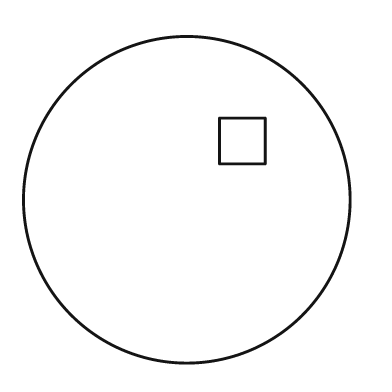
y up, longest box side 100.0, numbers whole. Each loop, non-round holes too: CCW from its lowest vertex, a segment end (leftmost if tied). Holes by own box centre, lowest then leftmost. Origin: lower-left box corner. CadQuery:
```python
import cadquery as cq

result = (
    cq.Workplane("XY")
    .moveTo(50.0, 50.0)
    .circle(50.0)
    .moveTo(60.0, 61.0)
    .lineTo(74.0, 61.0)
    .lineTo(74.0, 75.0)
    .lineTo(60.0, 75.0)
    .close()
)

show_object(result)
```